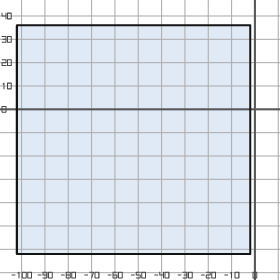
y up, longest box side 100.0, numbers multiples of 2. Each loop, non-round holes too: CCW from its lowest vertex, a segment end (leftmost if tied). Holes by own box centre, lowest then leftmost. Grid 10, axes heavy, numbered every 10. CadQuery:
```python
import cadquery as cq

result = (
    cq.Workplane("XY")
    .moveTo(-102.0, -62.0)
    .lineTo(-2.0, -62.0)
    .lineTo(-2.0, 36.0)
    .lineTo(-102.0, 36.0)
    .close()
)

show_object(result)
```